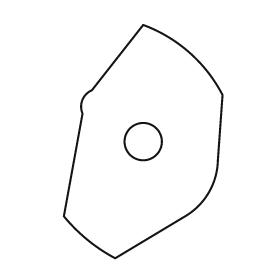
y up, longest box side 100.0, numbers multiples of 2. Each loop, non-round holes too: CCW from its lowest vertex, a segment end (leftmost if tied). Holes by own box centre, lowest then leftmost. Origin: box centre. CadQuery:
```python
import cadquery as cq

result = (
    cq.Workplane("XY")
    .moveTo(-12.0, -50.0)
    .lineTo(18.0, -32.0)
    .threePointArc((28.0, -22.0), (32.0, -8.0))
    .lineTo(34.0, 20.0)
    .threePointArc((20.0, 38.0), (0.0, 50.0))
    .lineTo(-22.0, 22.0)
    .threePointArc((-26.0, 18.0), (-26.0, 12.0))
    .lineTo(-34.0, -32.0)
    .threePointArc((-24.0, -42.0), (-12.0, -50.0))
    .close()
    .moveTo(0.0, 0.0)
    .circle(8.0)
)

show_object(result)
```